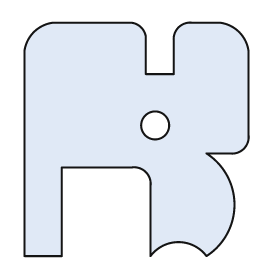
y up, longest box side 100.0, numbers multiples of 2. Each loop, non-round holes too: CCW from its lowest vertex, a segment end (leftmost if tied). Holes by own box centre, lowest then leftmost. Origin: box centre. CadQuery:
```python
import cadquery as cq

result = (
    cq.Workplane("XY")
    .moveTo(-48.0, -50.0)
    .lineTo(-32.0, -50.0)
    .lineTo(-32.0, -12.0)
    .lineTo(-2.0, -12.0)
    .threePointArc((4.0, -14.0), (6.0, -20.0))
    .lineTo(6.0, -50.0)
    .threePointArc((18.0, -44.0), (30.0, -50.0))
    .threePointArc((42.0, -28.0), (30.0, -6.0))
    .lineTo(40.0, -6.0)
    .threePointArc((46.0, -4.0), (48.0, 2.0))
    .lineTo(48.0, 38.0)
    .threePointArc((44.0, 46.0), (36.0, 50.0))
    .lineTo(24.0, 50.0)
    .threePointArc((18.0, 48.0), (16.0, 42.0))
    .lineTo(16.0, 28.0)
    .lineTo(4.0, 28.0)
    .lineTo(4.0, 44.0)
    .threePointArc((2.0, 48.0), (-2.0, 50.0))
    .lineTo(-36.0, 50.0)
    .threePointArc((-44.0, 46.0), (-48.0, 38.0))
    .close()
    .moveTo(8.0, 6.0)
    .circle(6.0)
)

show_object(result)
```